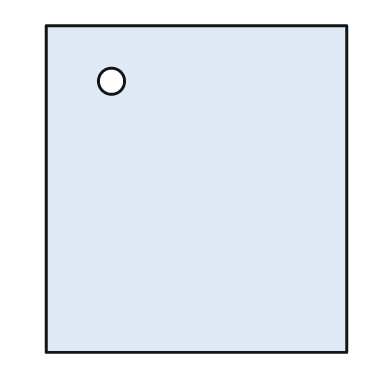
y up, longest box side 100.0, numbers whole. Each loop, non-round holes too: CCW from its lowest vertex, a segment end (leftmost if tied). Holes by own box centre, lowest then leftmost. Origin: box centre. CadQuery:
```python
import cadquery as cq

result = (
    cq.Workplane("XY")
    .moveTo(-46.0, -50.0)
    .lineTo(46.0, -50.0)
    .lineTo(46.0, 50.0)
    .lineTo(-46.0, 50.0)
    .close()
    .moveTo(-26.0, 33.0)
    .circle(4.0)
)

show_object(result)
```